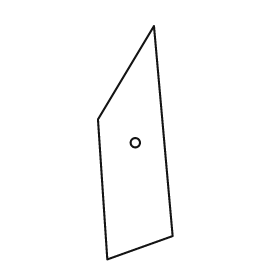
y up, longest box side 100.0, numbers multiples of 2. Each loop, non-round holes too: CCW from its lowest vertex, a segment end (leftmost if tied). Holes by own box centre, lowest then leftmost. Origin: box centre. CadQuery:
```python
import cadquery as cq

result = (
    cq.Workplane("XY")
    .moveTo(-12.0, -50.0)
    .lineTo(16.0, -40.0)
    .lineTo(8.0, 50.0)
    .lineTo(-16.0, 10.0)
    .close()
    .moveTo(0.0, 0.0)
    .circle(2.0)
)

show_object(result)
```